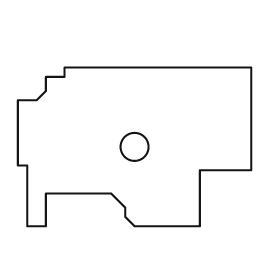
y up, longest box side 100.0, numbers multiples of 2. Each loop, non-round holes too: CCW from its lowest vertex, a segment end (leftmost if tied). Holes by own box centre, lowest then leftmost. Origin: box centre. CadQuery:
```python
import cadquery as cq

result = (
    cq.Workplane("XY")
    .moveTo(-46.0, -34.0)
    .lineTo(-38.0, -34.0)
    .lineTo(-38.0, -20.0)
    .lineTo(-10.0, -20.0)
    .lineTo(-4.0, -26.0)
    .lineTo(-4.0, -30.0)
    .lineTo(0.0, -34.0)
    .lineTo(28.0, -34.0)
    .lineTo(28.0, -10.0)
    .lineTo(50.0, -10.0)
    .lineTo(50.0, 34.0)
    .lineTo(-30.0, 34.0)
    .lineTo(-30.0, 30.0)
    .lineTo(-38.0, 30.0)
    .lineTo(-38.0, 24.0)
    .lineTo(-42.0, 20.0)
    .lineTo(-50.0, 20.0)
    .lineTo(-50.0, -8.0)
    .lineTo(-46.0, -8.0)
    .close()
    .moveTo(0.0, 0.0)
    .circle(6.0)
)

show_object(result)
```